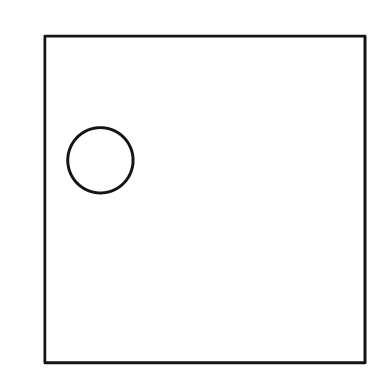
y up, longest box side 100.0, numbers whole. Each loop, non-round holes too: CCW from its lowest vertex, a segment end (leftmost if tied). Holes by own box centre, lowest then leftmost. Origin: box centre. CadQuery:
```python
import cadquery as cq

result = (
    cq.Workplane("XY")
    .moveTo(-49.0, -50.0)
    .lineTo(49.0, -50.0)
    .lineTo(49.0, 50.0)
    .lineTo(-49.0, 50.0)
    .close()
    .moveTo(-32.0, 12.0)
    .circle(10.0)
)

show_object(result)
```